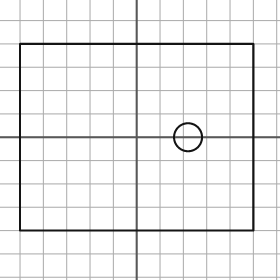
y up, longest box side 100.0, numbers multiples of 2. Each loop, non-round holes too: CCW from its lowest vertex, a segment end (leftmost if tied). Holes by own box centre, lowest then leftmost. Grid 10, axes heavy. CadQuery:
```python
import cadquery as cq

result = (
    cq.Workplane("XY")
    .moveTo(-50.0, -40.0)
    .lineTo(50.0, -40.0)
    .lineTo(50.0, 40.0)
    .lineTo(-50.0, 40.0)
    .close()
    .moveTo(22.0, 0.0)
    .circle(6.0)
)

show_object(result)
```